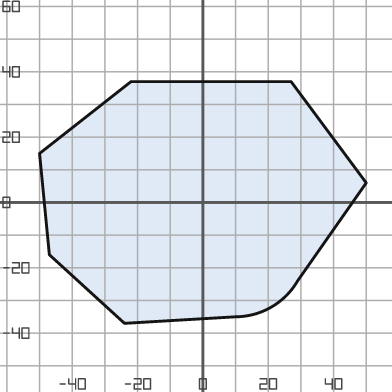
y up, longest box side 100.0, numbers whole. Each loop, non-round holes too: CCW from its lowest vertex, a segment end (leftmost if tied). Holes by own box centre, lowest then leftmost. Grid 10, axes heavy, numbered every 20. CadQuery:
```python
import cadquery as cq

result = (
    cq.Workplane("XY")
    .moveTo(-24.0, -37.0)
    .lineTo(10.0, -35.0)
    .threePointArc((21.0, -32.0), (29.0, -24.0))
    .lineTo(50.0, 6.0)
    .lineTo(27.0, 37.0)
    .lineTo(-22.0, 37.0)
    .lineTo(-50.0, 15.0)
    .lineTo(-47.0, -16.0)
    .close()
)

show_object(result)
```